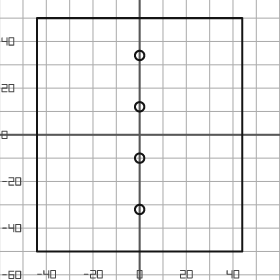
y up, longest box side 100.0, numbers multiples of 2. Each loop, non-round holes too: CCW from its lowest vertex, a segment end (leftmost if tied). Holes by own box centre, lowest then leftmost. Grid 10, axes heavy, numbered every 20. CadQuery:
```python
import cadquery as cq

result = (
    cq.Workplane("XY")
    .moveTo(-44.0, -50.0)
    .lineTo(44.0, -50.0)
    .lineTo(44.0, 50.0)
    .lineTo(-44.0, 50.0)
    .close()
    .moveTo(0.0, -32.0)
    .circle(2.0)
    .moveTo(0.0, -10.0)
    .circle(2.0)
    .moveTo(0.0, 12.0)
    .circle(2.0)
    .moveTo(0.0, 34.0)
    .circle(2.0)
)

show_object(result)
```